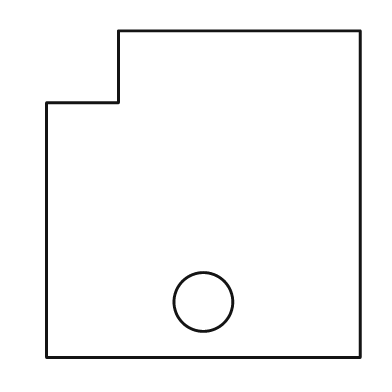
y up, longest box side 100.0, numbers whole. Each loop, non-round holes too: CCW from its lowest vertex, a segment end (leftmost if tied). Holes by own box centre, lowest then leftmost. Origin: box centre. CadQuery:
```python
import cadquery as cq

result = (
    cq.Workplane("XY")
    .moveTo(-48.0, -50.0)
    .lineTo(48.0, -50.0)
    .lineTo(48.0, 50.0)
    .lineTo(-26.0, 50.0)
    .lineTo(-26.0, 28.0)
    .lineTo(-48.0, 28.0)
    .close()
    .moveTo(0.0, -33.0)
    .circle(9.0)
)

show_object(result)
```